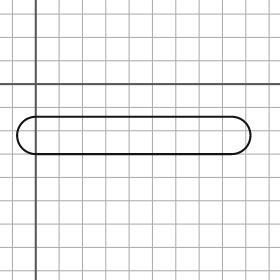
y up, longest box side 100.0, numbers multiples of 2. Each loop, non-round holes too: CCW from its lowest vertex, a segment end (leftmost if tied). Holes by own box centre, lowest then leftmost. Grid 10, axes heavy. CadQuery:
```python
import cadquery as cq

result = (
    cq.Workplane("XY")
    .moveTo(0.0, -30.0)
    .lineTo(84.0, -30.0)
    .threePointArc((92.0, -22.0), (84.0, -14.0))
    .lineTo(0.0, -14.0)
    .threePointArc((-8.0, -22.0), (0.0, -30.0))
    .close()
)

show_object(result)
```